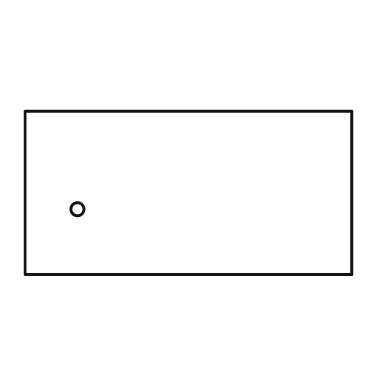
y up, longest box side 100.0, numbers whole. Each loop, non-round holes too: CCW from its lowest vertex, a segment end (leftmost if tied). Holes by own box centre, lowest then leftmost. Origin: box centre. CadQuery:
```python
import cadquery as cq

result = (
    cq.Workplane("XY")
    .moveTo(-50.0, -25.0)
    .lineTo(50.0, -25.0)
    .lineTo(50.0, 25.0)
    .lineTo(-50.0, 25.0)
    .close()
    .moveTo(-34.0, -5.0)
    .circle(2.0)
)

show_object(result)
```